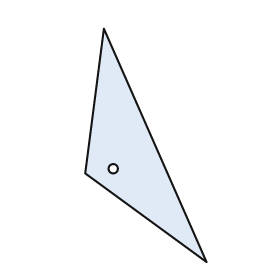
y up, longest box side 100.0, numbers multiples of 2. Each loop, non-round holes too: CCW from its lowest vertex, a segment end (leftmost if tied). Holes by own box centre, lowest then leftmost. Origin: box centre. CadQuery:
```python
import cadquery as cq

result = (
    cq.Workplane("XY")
    .moveTo(26.0, -50.0)
    .lineTo(-18.0, 50.0)
    .lineTo(-26.0, -12.0)
    .close()
    .moveTo(-14.0, -10.0)
    .circle(2.0)
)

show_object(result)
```